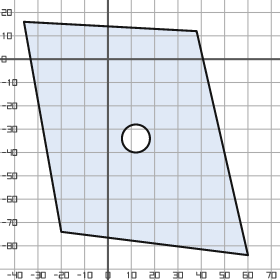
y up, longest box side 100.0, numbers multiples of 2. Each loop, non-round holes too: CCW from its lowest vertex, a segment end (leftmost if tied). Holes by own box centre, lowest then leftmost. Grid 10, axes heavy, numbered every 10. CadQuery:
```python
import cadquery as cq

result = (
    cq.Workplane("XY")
    .moveTo(60.0, -84.0)
    .lineTo(38.0, 12.0)
    .lineTo(-36.0, 16.0)
    .lineTo(-20.0, -74.0)
    .close()
    .moveTo(12.0, -34.0)
    .circle(6.0)
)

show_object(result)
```